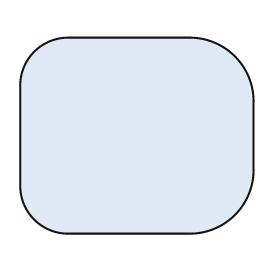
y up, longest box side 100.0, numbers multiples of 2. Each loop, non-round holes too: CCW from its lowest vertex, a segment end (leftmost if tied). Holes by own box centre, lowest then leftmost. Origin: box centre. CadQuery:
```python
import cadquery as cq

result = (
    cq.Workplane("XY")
    .moveTo(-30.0, -42.0)
    .lineTo(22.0, -42.0)
    .threePointArc((42.0, -34.0), (50.0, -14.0))
    .lineTo(50.0, 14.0)
    .threePointArc((42.0, 34.0), (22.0, 42.0))
    .lineTo(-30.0, 42.0)
    .threePointArc((-44.0, 36.0), (-50.0, 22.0))
    .lineTo(-50.0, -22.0)
    .threePointArc((-44.0, -36.0), (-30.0, -42.0))
    .close()
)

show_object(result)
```